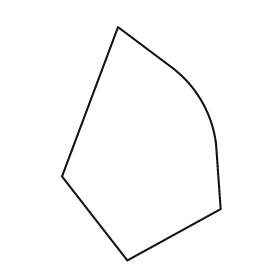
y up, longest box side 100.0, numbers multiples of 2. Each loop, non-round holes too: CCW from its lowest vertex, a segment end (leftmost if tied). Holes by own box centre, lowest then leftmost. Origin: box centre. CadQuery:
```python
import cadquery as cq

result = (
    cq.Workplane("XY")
    .moveTo(-6.0, -50.0)
    .lineTo(34.0, -28.0)
    .lineTo(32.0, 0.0)
    .threePointArc((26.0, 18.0), (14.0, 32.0))
    .lineTo(-10.0, 50.0)
    .lineTo(-34.0, -14.0)
    .close()
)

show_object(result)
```